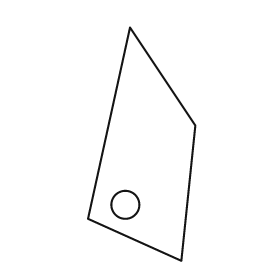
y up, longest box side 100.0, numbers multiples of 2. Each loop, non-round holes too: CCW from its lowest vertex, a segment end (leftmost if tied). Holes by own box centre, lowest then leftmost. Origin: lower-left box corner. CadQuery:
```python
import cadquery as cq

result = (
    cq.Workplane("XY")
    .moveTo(40.0, 0.0)
    .lineTo(46.0, 58.0)
    .lineTo(18.0, 100.0)
    .lineTo(0.0, 18.0)
    .close()
    .moveTo(16.0, 24.0)
    .circle(6.0)
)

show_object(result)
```